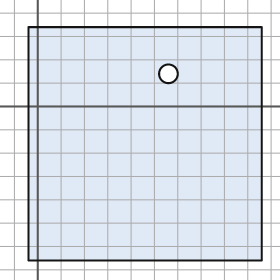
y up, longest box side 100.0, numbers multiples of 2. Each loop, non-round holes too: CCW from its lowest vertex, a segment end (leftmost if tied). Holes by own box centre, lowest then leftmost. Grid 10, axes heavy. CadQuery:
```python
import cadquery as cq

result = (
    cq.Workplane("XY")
    .moveTo(-4.0, -66.0)
    .lineTo(96.0, -66.0)
    .lineTo(96.0, 34.0)
    .lineTo(-4.0, 34.0)
    .close()
    .moveTo(56.0, 14.0)
    .circle(4.0)
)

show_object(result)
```